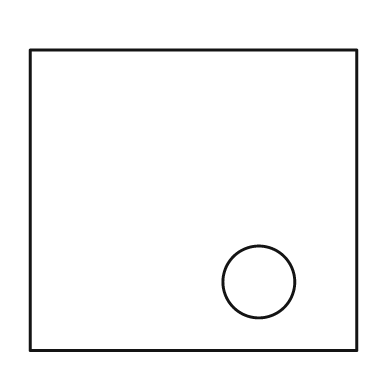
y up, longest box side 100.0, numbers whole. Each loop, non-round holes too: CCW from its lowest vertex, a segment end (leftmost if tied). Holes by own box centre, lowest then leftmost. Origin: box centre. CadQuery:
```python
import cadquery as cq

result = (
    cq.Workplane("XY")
    .moveTo(-50.0, -46.0)
    .lineTo(50.0, -46.0)
    .lineTo(50.0, 46.0)
    .lineTo(-50.0, 46.0)
    .close()
    .moveTo(20.0, -25.0)
    .circle(11.0)
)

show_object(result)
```